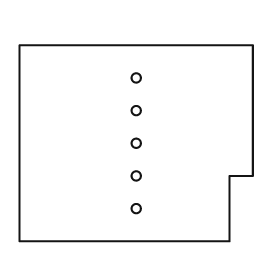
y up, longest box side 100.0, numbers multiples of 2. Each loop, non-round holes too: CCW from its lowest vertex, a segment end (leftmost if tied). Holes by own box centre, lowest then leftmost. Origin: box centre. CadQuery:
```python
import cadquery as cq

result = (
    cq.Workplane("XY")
    .moveTo(-50.0, -42.0)
    .lineTo(40.0, -42.0)
    .lineTo(40.0, -14.0)
    .lineTo(50.0, -14.0)
    .lineTo(50.0, 42.0)
    .lineTo(-50.0, 42.0)
    .close()
    .moveTo(0.0, -28.0)
    .circle(2.0)
    .moveTo(0.0, -14.0)
    .circle(2.0)
    .moveTo(0.0, 0.0)
    .circle(2.0)
    .moveTo(0.0, 14.0)
    .circle(2.0)
    .moveTo(0.0, 28.0)
    .circle(2.0)
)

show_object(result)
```